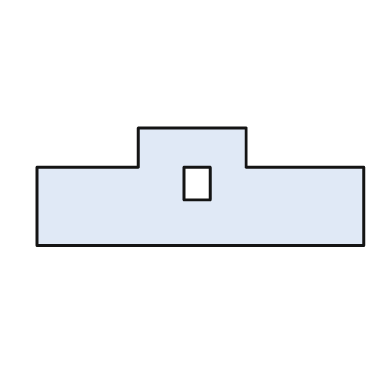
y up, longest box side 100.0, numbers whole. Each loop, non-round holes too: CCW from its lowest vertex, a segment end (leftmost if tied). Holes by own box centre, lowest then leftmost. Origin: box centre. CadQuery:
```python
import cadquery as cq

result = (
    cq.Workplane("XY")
    .moveTo(-50.0, -18.0)
    .lineTo(50.0, -18.0)
    .lineTo(50.0, 6.0)
    .lineTo(14.0, 6.0)
    .lineTo(14.0, 18.0)
    .lineTo(-19.0, 18.0)
    .lineTo(-19.0, 6.0)
    .lineTo(-50.0, 6.0)
    .close()
    .moveTo(-5.0, -4.0)
    .lineTo(3.0, -4.0)
    .lineTo(3.0, 6.0)
    .lineTo(-5.0, 6.0)
    .close()
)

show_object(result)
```